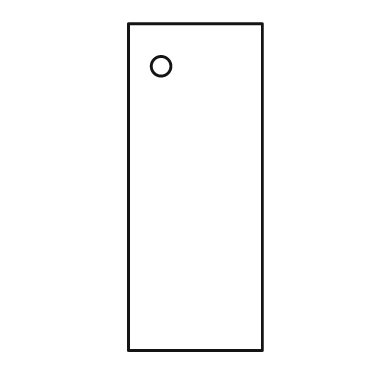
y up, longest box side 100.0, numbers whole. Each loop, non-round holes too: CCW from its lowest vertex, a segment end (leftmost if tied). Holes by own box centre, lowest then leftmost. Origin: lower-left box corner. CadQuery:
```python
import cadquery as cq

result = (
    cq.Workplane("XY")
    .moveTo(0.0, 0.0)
    .lineTo(41.0, 0.0)
    .lineTo(41.0, 100.0)
    .lineTo(0.0, 100.0)
    .close()
    .moveTo(10.0, 87.0)
    .circle(3.0)
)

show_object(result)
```